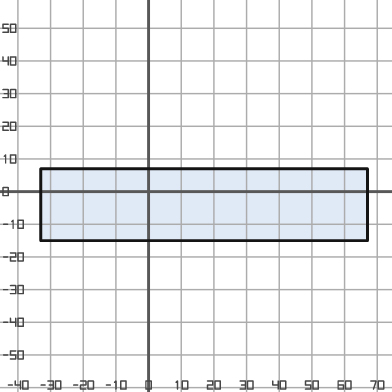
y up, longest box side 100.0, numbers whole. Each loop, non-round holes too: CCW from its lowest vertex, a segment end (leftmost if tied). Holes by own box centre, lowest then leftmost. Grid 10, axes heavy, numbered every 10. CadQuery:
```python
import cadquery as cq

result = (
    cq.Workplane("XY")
    .moveTo(-33.0, -15.0)
    .lineTo(67.0, -15.0)
    .lineTo(67.0, 7.0)
    .lineTo(-33.0, 7.0)
    .close()
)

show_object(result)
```